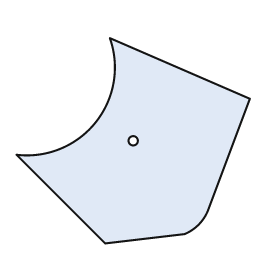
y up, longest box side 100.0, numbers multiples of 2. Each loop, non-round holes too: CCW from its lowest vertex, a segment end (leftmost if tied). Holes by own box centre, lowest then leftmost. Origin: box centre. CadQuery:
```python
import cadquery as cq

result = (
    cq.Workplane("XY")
    .moveTo(-12.0, -44.0)
    .lineTo(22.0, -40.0)
    .threePointArc((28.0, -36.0), (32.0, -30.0))
    .lineTo(50.0, 18.0)
    .lineTo(-10.0, 44.0)
    .threePointArc((-16.0, 8.0), (-50.0, -6.0))
    .close()
    .moveTo(0.0, 0.0)
    .circle(2.0)
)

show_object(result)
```